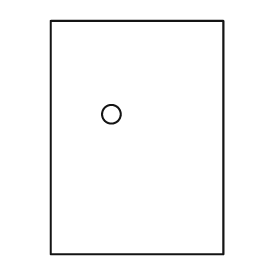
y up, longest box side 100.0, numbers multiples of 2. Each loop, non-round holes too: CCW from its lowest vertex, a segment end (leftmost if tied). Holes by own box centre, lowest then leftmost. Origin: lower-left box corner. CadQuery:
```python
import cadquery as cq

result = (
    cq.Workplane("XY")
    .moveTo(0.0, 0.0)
    .lineTo(74.0, 0.0)
    .lineTo(74.0, 100.0)
    .lineTo(0.0, 100.0)
    .close()
    .moveTo(26.0, 60.0)
    .circle(4.0)
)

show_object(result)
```